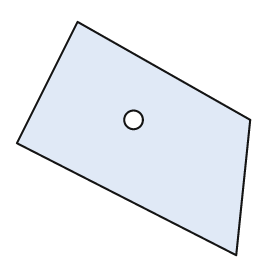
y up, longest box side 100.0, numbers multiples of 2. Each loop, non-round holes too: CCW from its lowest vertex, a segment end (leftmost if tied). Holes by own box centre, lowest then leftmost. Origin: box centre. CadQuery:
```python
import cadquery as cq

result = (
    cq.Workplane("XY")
    .moveTo(44.0, -50.0)
    .lineTo(50.0, 8.0)
    .lineTo(-24.0, 50.0)
    .lineTo(-50.0, -2.0)
    .close()
    .moveTo(0.0, 8.0)
    .circle(4.0)
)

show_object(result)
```